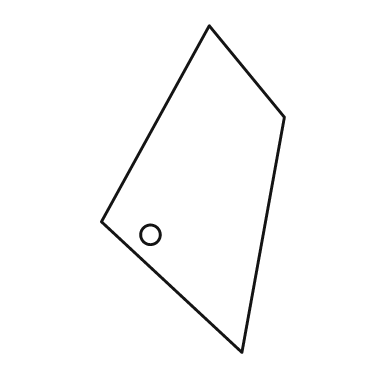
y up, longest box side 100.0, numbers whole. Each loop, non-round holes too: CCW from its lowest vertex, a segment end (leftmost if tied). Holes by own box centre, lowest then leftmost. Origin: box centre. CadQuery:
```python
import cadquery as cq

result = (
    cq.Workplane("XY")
    .moveTo(15.0, -50.0)
    .lineTo(28.0, 22.0)
    .lineTo(5.0, 50.0)
    .lineTo(-28.0, -10.0)
    .close()
    .moveTo(-13.0, -14.0)
    .circle(3.0)
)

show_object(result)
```